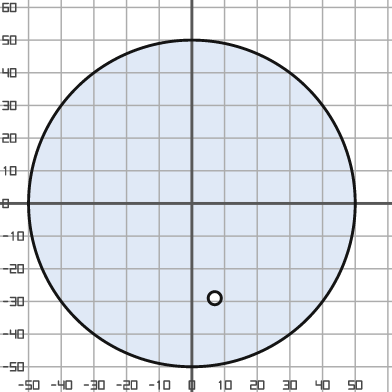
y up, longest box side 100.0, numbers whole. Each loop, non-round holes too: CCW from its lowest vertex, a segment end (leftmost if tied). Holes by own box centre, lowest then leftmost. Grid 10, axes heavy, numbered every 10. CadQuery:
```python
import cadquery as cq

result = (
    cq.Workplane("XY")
    .moveTo(0.0, 0.0)
    .circle(50.0)
    .moveTo(7.0, -29.0)
    .circle(2.0)
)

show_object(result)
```